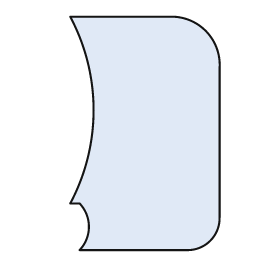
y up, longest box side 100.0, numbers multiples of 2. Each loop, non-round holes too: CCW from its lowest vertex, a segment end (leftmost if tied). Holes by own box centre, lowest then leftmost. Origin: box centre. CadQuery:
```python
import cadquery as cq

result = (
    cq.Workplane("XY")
    .moveTo(-28.0, -50.0)
    .lineTo(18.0, -50.0)
    .threePointArc((28.0, -46.0), (32.0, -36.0))
    .lineTo(32.0, 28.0)
    .threePointArc((26.0, 44.0), (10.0, 50.0))
    .lineTo(-32.0, 50.0)
    .threePointArc((-22.0, 10.0), (-32.0, -30.0))
    .lineTo(-28.0, -30.0)
    .threePointArc((-24.0, -40.0), (-28.0, -50.0))
    .close()
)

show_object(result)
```